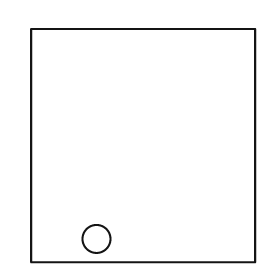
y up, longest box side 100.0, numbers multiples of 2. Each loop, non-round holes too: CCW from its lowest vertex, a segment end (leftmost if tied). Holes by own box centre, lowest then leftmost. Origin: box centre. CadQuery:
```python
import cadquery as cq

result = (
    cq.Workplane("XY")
    .moveTo(-48.0, -50.0)
    .lineTo(48.0, -50.0)
    .lineTo(48.0, 50.0)
    .lineTo(-48.0, 50.0)
    .close()
    .moveTo(-20.0, -40.0)
    .circle(6.0)
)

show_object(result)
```